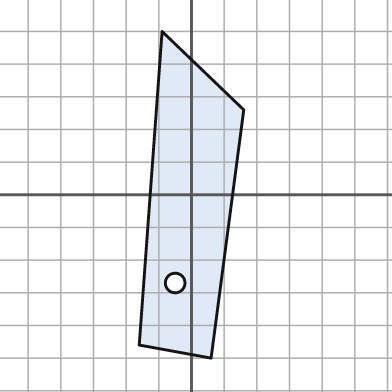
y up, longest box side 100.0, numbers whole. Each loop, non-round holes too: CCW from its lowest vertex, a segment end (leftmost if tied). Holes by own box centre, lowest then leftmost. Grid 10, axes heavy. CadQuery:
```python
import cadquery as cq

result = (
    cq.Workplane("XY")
    .moveTo(6.0, -50.0)
    .lineTo(16.0, 26.0)
    .lineTo(-9.0, 50.0)
    .lineTo(-16.0, -46.0)
    .close()
    .moveTo(-5.0, -27.0)
    .circle(3.0)
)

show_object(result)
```